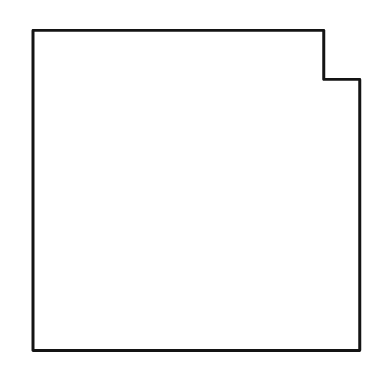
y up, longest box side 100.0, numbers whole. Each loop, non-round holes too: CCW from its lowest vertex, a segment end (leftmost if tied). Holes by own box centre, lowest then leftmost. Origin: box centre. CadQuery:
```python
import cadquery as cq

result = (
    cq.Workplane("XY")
    .moveTo(-50.0, -49.0)
    .lineTo(50.0, -49.0)
    .lineTo(50.0, 34.0)
    .lineTo(39.0, 34.0)
    .lineTo(39.0, 49.0)
    .lineTo(-50.0, 49.0)
    .close()
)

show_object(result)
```